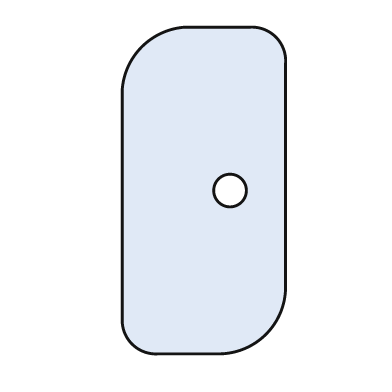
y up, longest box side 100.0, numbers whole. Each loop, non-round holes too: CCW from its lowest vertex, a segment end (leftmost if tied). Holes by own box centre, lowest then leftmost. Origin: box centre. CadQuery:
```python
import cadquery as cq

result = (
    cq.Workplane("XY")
    .moveTo(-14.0, -50.0)
    .lineTo(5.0, -50.0)
    .threePointArc((19.0, -44.0), (25.0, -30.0))
    .lineTo(25.0, 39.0)
    .threePointArc((22.0, 47.0), (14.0, 50.0))
    .lineTo(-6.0, 50.0)
    .threePointArc((-19.0, 44.0), (-25.0, 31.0))
    .lineTo(-25.0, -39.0)
    .threePointArc((-22.0, -47.0), (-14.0, -50.0))
    .close()
    .moveTo(8.0, 0.0)
    .circle(5.0)
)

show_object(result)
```